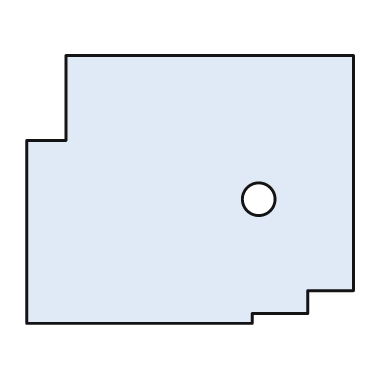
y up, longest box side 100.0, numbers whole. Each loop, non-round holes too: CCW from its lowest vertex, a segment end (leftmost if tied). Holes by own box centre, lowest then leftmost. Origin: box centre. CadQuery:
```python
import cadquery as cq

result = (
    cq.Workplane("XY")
    .moveTo(-50.0, -41.0)
    .lineTo(19.0, -41.0)
    .lineTo(19.0, -38.0)
    .lineTo(36.0, -38.0)
    .lineTo(36.0, -31.0)
    .lineTo(50.0, -31.0)
    .lineTo(50.0, 41.0)
    .lineTo(-38.0, 41.0)
    .lineTo(-38.0, 15.0)
    .lineTo(-50.0, 15.0)
    .close()
    .moveTo(21.0, -3.0)
    .circle(5.0)
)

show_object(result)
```